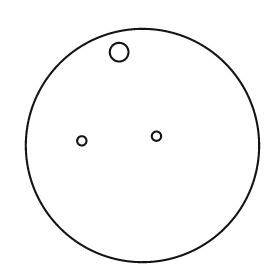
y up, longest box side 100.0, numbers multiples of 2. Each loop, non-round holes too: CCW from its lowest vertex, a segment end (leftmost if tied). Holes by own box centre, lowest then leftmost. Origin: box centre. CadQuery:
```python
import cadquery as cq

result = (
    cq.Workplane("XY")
    .moveTo(0.0, 0.0)
    .circle(50.0)
    .moveTo(-26.0, 2.0)
    .circle(2.0)
    .moveTo(6.0, 4.0)
    .circle(2.0)
    .moveTo(-10.0, 40.0)
    .circle(4.0)
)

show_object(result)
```